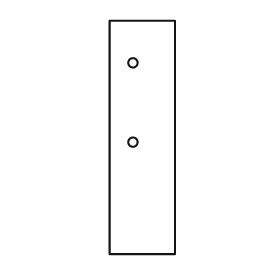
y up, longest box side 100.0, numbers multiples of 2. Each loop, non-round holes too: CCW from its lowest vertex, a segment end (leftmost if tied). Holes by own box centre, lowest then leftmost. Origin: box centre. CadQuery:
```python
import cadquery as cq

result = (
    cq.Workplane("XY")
    .moveTo(-14.0, -50.0)
    .lineTo(14.0, -50.0)
    .lineTo(14.0, 50.0)
    .lineTo(-14.0, 50.0)
    .close()
    .moveTo(-4.0, -2.0)
    .circle(2.0)
    .moveTo(-4.0, 32.0)
    .circle(2.0)
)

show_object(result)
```